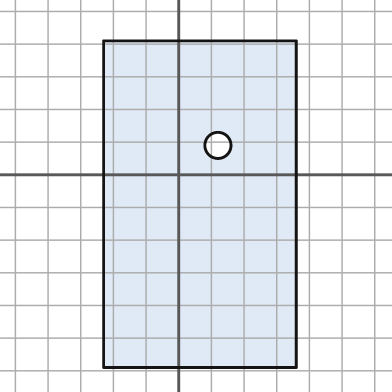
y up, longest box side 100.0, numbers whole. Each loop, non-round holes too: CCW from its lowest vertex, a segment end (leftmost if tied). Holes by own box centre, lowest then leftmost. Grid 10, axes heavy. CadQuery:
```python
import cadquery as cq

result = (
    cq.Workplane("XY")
    .moveTo(-23.0, -59.0)
    .lineTo(36.0, -59.0)
    .lineTo(36.0, 41.0)
    .lineTo(-23.0, 41.0)
    .close()
    .moveTo(12.0, 9.0)
    .circle(4.0)
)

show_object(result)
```